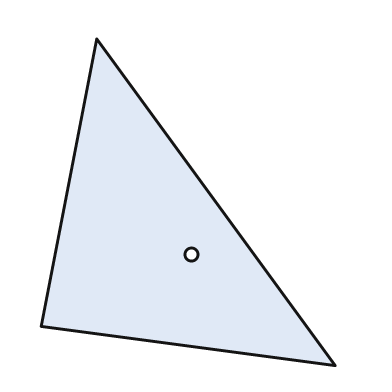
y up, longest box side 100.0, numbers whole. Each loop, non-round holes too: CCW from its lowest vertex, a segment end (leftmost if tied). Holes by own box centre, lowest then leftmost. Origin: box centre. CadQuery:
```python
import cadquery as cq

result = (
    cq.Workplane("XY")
    .moveTo(45.0, -50.0)
    .lineTo(-28.0, 50.0)
    .lineTo(-45.0, -38.0)
    .close()
    .moveTo(1.0, -16.0)
    .circle(2.0)
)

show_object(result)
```